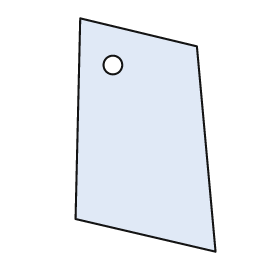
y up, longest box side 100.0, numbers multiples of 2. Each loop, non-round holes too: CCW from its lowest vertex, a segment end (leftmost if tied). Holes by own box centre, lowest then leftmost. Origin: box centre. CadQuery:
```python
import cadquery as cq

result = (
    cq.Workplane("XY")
    .moveTo(30.0, -50.0)
    .lineTo(22.0, 38.0)
    .lineTo(-28.0, 50.0)
    .lineTo(-30.0, -36.0)
    .close()
    .moveTo(-14.0, 30.0)
    .circle(4.0)
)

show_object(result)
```